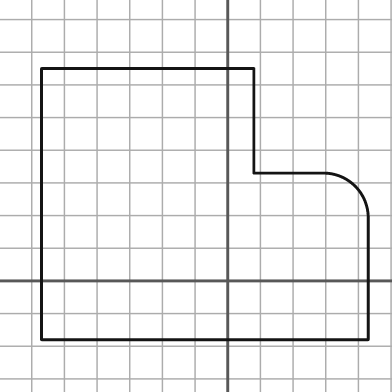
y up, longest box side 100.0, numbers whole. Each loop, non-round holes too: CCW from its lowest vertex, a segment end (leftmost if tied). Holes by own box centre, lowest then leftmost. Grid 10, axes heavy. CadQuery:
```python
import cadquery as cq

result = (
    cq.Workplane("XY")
    .moveTo(-57.0, -18.0)
    .lineTo(43.0, -18.0)
    .lineTo(43.0, 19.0)
    .threePointArc((39.0, 29.0), (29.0, 33.0))
    .lineTo(8.0, 33.0)
    .lineTo(8.0, 65.0)
    .lineTo(-57.0, 65.0)
    .close()
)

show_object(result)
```